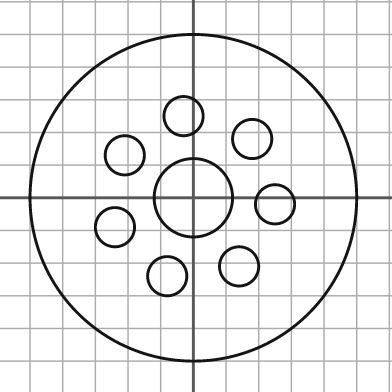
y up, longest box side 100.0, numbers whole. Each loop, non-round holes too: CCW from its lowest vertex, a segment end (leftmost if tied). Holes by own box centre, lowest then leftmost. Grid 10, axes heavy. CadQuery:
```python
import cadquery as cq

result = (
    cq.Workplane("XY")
    .moveTo(0.0, 0.0)
    .circle(50.0)
    .moveTo(-8.0, -24.0)
    .circle(6.0)
    .moveTo(14.0, -21.0)
    .circle(6.0)
    .moveTo(-24.0, -9.0)
    .circle(6.0)
    .moveTo(25.0, -2.0)
    .circle(6.0)
    .moveTo(0.0, 0.0)
    .circle(12.0)
    .moveTo(-21.0, 13.0)
    .circle(6.0)
    .moveTo(18.0, 18.0)
    .circle(6.0)
    .moveTo(-3.0, 25.0)
    .circle(6.0)
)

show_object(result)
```